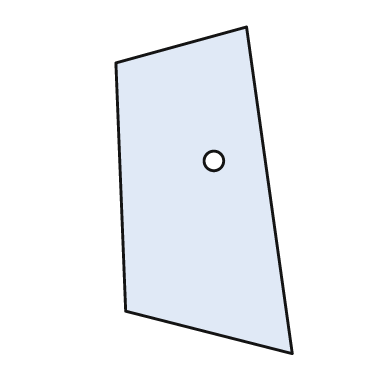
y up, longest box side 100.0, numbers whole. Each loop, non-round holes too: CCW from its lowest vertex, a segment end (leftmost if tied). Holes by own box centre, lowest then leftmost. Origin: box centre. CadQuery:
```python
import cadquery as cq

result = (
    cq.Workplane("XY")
    .moveTo(27.0, -50.0)
    .lineTo(13.0, 50.0)
    .lineTo(-27.0, 39.0)
    .lineTo(-24.0, -37.0)
    .close()
    .moveTo(3.0, 9.0)
    .circle(3.0)
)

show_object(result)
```